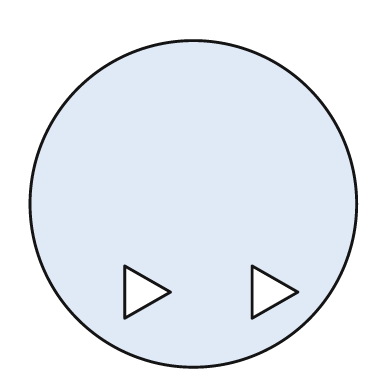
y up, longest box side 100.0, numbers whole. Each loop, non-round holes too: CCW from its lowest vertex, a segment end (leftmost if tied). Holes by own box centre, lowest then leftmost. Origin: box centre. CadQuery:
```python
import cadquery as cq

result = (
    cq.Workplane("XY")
    .moveTo(0.0, 0.0)
    .circle(50.0)
    .moveTo(-21.0, -35.0)
    .lineTo(-7.0, -27.0)
    .lineTo(-21.0, -19.0)
    .close()
    .moveTo(18.0, -35.0)
    .lineTo(32.0, -27.0)
    .lineTo(18.0, -19.0)
    .close()
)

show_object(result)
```